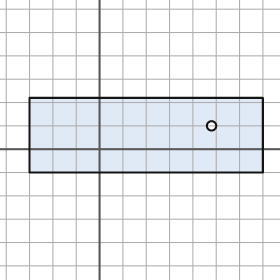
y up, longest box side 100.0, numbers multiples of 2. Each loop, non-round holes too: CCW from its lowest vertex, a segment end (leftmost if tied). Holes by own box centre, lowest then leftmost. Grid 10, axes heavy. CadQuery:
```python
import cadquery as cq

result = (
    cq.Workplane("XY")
    .moveTo(-30.0, -10.0)
    .lineTo(70.0, -10.0)
    .lineTo(70.0, 22.0)
    .lineTo(-30.0, 22.0)
    .close()
    .moveTo(48.0, 10.0)
    .circle(2.0)
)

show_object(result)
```